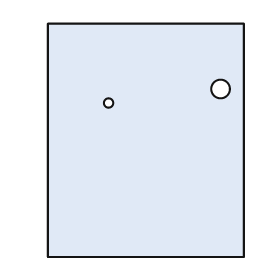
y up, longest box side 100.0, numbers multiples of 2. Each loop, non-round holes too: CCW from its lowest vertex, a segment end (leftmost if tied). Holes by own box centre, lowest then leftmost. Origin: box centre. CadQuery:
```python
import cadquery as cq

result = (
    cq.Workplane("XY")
    .moveTo(-42.0, -50.0)
    .lineTo(42.0, -50.0)
    .lineTo(42.0, 50.0)
    .lineTo(-42.0, 50.0)
    .close()
    .moveTo(-16.0, 16.0)
    .circle(2.0)
    .moveTo(32.0, 22.0)
    .circle(4.0)
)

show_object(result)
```